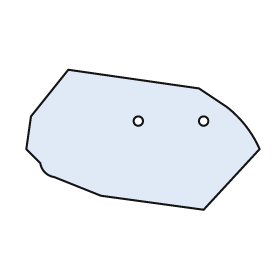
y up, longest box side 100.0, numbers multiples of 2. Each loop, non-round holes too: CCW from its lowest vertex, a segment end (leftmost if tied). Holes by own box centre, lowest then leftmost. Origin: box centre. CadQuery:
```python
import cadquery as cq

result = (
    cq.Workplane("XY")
    .moveTo(26.0, -30.0)
    .lineTo(50.0, -4.0)
    .threePointArc((44.0, 6.0), (36.0, 14.0))
    .lineTo(24.0, 22.0)
    .lineTo(-32.0, 30.0)
    .lineTo(-48.0, 10.0)
    .lineTo(-50.0, -4.0)
    .lineTo(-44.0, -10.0)
    .threePointArc((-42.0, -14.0), (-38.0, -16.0))
    .lineTo(-18.0, -24.0)
    .close()
    .moveTo(-2.0, 8.0)
    .circle(2.0)
    .moveTo(26.0, 8.0)
    .circle(2.0)
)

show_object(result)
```